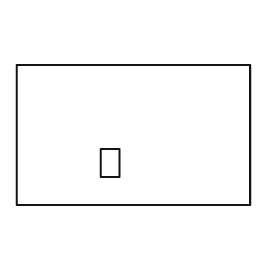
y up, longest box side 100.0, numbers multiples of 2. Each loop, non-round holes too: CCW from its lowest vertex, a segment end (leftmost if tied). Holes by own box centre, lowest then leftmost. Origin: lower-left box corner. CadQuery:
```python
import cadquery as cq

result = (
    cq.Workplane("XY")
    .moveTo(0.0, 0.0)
    .lineTo(100.0, 0.0)
    .lineTo(100.0, 60.0)
    .lineTo(0.0, 60.0)
    .close()
    .moveTo(36.0, 12.0)
    .lineTo(44.0, 12.0)
    .lineTo(44.0, 24.0)
    .lineTo(36.0, 24.0)
    .close()
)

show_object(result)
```